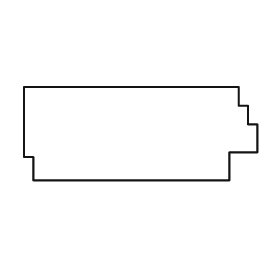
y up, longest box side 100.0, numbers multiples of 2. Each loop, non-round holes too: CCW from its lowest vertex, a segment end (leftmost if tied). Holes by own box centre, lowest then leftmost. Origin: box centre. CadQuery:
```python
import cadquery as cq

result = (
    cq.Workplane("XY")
    .moveTo(-46.0, -20.0)
    .lineTo(38.0, -20.0)
    .lineTo(38.0, -8.0)
    .lineTo(50.0, -8.0)
    .lineTo(50.0, 4.0)
    .lineTo(46.0, 4.0)
    .lineTo(46.0, 12.0)
    .lineTo(42.0, 12.0)
    .lineTo(42.0, 20.0)
    .lineTo(-50.0, 20.0)
    .lineTo(-50.0, -10.0)
    .lineTo(-46.0, -10.0)
    .close()
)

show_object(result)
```